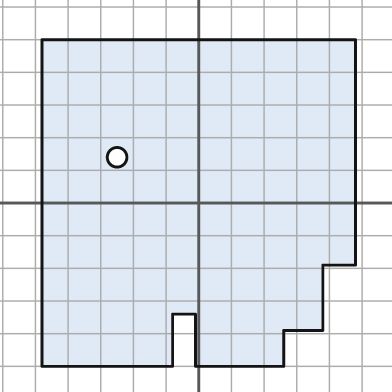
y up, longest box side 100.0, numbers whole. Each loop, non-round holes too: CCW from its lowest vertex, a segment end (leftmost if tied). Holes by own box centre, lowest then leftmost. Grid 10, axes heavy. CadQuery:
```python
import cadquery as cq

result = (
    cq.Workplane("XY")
    .moveTo(-48.0, -50.0)
    .lineTo(-8.0, -50.0)
    .lineTo(-8.0, -34.0)
    .lineTo(-1.0, -34.0)
    .lineTo(-1.0, -50.0)
    .lineTo(26.0, -50.0)
    .lineTo(26.0, -39.0)
    .lineTo(38.0, -39.0)
    .lineTo(38.0, -19.0)
    .lineTo(48.0, -19.0)
    .lineTo(48.0, 50.0)
    .lineTo(-48.0, 50.0)
    .close()
    .moveTo(-25.0, 14.0)
    .circle(3.0)
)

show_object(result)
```